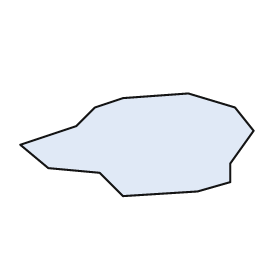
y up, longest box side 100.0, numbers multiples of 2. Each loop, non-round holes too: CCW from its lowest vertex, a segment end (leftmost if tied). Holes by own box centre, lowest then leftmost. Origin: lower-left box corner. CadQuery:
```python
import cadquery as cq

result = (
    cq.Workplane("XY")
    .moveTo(44.0, 0.0)
    .lineTo(76.0, 2.0)
    .lineTo(90.0, 6.0)
    .lineTo(90.0, 14.0)
    .lineTo(100.0, 28.0)
    .lineTo(92.0, 38.0)
    .lineTo(72.0, 44.0)
    .lineTo(44.0, 42.0)
    .lineTo(32.0, 38.0)
    .lineTo(24.0, 30.0)
    .lineTo(0.0, 22.0)
    .lineTo(12.0, 12.0)
    .lineTo(34.0, 10.0)
    .close()
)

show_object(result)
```